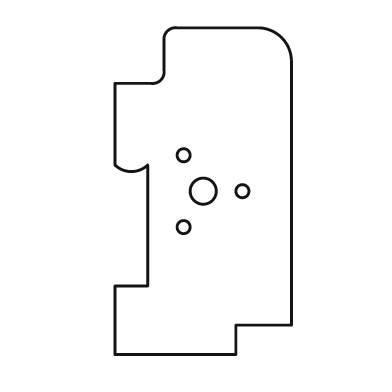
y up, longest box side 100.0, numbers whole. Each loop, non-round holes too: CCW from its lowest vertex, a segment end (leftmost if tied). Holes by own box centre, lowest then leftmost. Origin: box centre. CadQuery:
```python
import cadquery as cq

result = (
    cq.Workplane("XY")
    .moveTo(-27.0, -50.0)
    .lineTo(10.0, -50.0)
    .lineTo(10.0, -41.0)
    .lineTo(27.0, -41.0)
    .lineTo(27.0, 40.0)
    .threePointArc((24.0, 47.0), (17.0, 50.0))
    .lineTo(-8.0, 50.0)
    .threePointArc((-11.0, 49.0), (-12.0, 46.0))
    .lineTo(-12.0, 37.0)
    .threePointArc((-13.0, 34.0), (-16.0, 33.0))
    .lineTo(-27.0, 33.0)
    .lineTo(-27.0, 8.0)
    .threePointArc((-22.0, 6.0), (-17.0, 8.0))
    .lineTo(-17.0, -29.0)
    .lineTo(-27.0, -29.0)
    .close()
    .moveTo(-6.0, -11.0)
    .circle(2.0)
    .moveTo(0.0, 0.0)
    .circle(4.0)
    .moveTo(12.0, 0.0)
    .circle(2.0)
    .moveTo(-6.0, 11.0)
    .circle(2.0)
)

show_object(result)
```